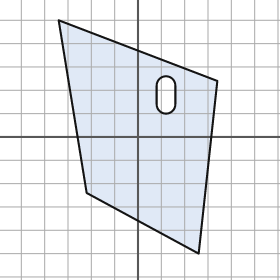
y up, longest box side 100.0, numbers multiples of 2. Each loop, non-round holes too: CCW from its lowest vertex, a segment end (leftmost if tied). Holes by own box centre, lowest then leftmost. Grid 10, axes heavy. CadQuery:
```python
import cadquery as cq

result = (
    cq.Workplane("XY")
    .moveTo(26.0, -50.0)
    .lineTo(34.0, 24.0)
    .lineTo(-34.0, 50.0)
    .lineTo(-22.0, -24.0)
    .close()
    .moveTo(8.0, 14.0)
    .threePointArc((12.0, 10.0), (16.0, 14.0))
    .lineTo(16.0, 22.0)
    .threePointArc((12.0, 26.0), (8.0, 22.0))
    .close()
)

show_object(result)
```